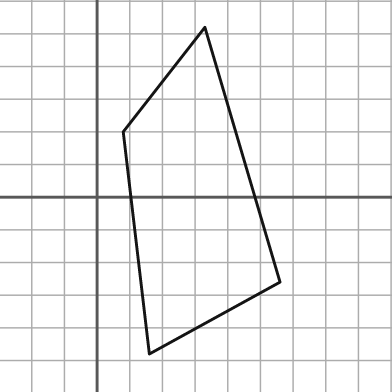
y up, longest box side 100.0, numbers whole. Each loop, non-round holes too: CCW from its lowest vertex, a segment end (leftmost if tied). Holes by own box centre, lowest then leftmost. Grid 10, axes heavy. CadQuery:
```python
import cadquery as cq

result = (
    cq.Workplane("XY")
    .moveTo(16.0, -48.0)
    .lineTo(56.0, -26.0)
    .lineTo(33.0, 52.0)
    .lineTo(8.0, 20.0)
    .close()
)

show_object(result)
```